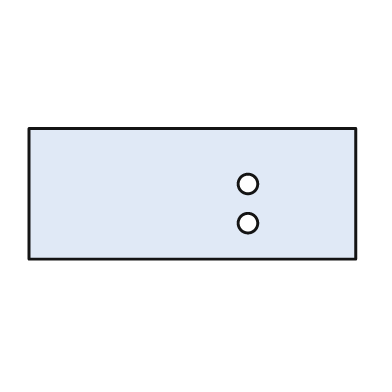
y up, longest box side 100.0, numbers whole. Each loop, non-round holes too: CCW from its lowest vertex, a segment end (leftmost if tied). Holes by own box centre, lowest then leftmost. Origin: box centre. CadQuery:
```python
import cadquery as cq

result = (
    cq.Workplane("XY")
    .moveTo(-50.0, -20.0)
    .lineTo(50.0, -20.0)
    .lineTo(50.0, 20.0)
    .lineTo(-50.0, 20.0)
    .close()
    .moveTo(17.0, -9.0)
    .circle(3.0)
    .moveTo(17.0, 3.0)
    .circle(3.0)
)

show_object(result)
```